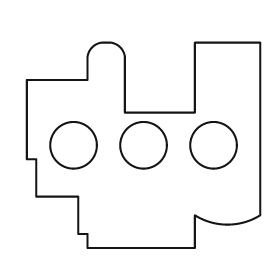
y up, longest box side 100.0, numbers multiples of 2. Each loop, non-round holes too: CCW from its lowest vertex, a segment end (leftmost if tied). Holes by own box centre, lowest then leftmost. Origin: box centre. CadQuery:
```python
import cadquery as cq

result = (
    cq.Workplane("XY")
    .moveTo(-24.0, -44.0)
    .lineTo(22.0, -44.0)
    .lineTo(22.0, -30.0)
    .threePointArc((36.0, -34.0), (50.0, -30.0))
    .lineTo(50.0, 44.0)
    .lineTo(22.0, 44.0)
    .lineTo(22.0, 14.0)
    .lineTo(-8.0, 14.0)
    .lineTo(-8.0, 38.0)
    .threePointArc((-10.0, 42.0), (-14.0, 44.0))
    .lineTo(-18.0, 44.0)
    .threePointArc((-22.0, 42.0), (-24.0, 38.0))
    .lineTo(-24.0, 28.0)
    .lineTo(-50.0, 28.0)
    .lineTo(-50.0, -6.0)
    .lineTo(-46.0, -6.0)
    .lineTo(-46.0, -22.0)
    .lineTo(-28.0, -22.0)
    .lineTo(-28.0, -38.0)
    .lineTo(-24.0, -38.0)
    .close()
    .moveTo(-30.0, 0.0)
    .circle(10.0)
    .moveTo(0.0, 0.0)
    .circle(10.0)
    .moveTo(30.0, 0.0)
    .circle(10.0)
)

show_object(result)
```